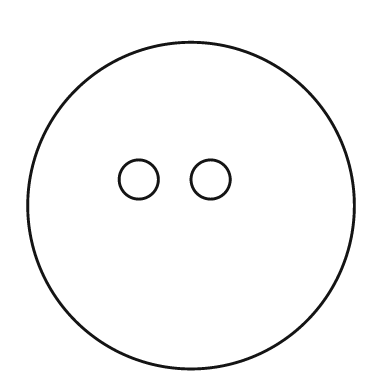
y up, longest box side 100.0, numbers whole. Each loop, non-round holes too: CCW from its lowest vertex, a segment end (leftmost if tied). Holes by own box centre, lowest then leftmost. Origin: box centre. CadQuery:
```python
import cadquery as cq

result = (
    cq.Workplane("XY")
    .moveTo(0.0, 0.0)
    .circle(50.0)
    .moveTo(-16.0, 8.0)
    .circle(6.0)
    .moveTo(6.0, 8.0)
    .circle(6.0)
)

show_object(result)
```